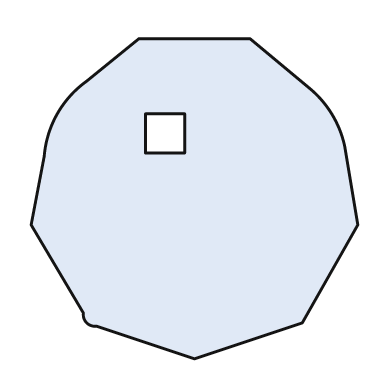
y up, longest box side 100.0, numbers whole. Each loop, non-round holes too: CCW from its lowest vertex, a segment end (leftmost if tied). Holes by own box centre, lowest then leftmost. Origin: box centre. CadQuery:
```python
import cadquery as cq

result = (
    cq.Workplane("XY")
    .moveTo(0.0, -49.0)
    .lineTo(33.0, -38.0)
    .lineTo(50.0, -8.0)
    .lineTo(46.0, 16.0)
    .threePointArc((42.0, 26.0), (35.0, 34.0))
    .lineTo(17.0, 49.0)
    .lineTo(-17.0, 49.0)
    .lineTo(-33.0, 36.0)
    .threePointArc((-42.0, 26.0), (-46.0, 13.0))
    .lineTo(-50.0, -8.0)
    .lineTo(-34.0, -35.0)
    .threePointArc((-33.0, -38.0), (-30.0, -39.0))
    .close()
    .moveTo(-15.0, 14.0)
    .lineTo(-3.0, 14.0)
    .lineTo(-3.0, 26.0)
    .lineTo(-15.0, 26.0)
    .close()
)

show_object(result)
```